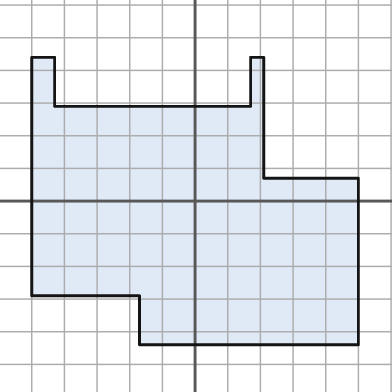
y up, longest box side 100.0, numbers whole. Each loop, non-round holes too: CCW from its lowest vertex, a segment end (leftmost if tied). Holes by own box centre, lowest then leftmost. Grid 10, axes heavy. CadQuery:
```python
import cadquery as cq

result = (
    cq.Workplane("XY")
    .moveTo(-17.0, -44.0)
    .lineTo(50.0, -44.0)
    .lineTo(50.0, 7.0)
    .lineTo(21.0, 7.0)
    .lineTo(21.0, 44.0)
    .lineTo(17.0, 44.0)
    .lineTo(17.0, 29.0)
    .lineTo(-43.0, 29.0)
    .lineTo(-43.0, 44.0)
    .lineTo(-50.0, 44.0)
    .lineTo(-50.0, -29.0)
    .lineTo(-17.0, -29.0)
    .close()
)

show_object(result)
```